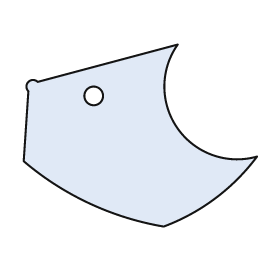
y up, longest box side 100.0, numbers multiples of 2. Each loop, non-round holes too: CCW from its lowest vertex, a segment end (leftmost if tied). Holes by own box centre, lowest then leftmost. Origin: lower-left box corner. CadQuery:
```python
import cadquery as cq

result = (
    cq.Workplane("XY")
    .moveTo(60.0, 0.0)
    .threePointArc((82.0, 12.0), (100.0, 30.0))
    .threePointArc((66.0, 42.0), (66.0, 78.0))
    .lineTo(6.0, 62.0)
    .threePointArc((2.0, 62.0), (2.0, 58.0))
    .lineTo(0.0, 28.0)
    .threePointArc((28.0, 10.0), (60.0, 0.0))
    .close()
    .moveTo(30.0, 56.0)
    .circle(4.0)
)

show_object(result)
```